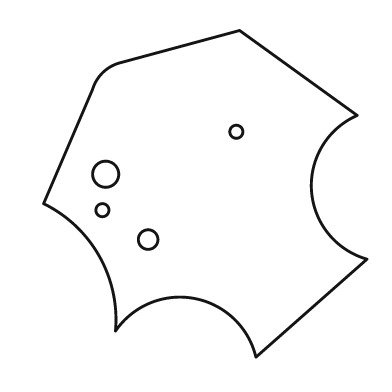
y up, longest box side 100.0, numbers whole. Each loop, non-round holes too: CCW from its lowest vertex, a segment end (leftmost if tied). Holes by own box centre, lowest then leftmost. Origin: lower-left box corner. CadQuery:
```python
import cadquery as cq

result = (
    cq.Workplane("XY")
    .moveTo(65.0, 0.0)
    .lineTo(99.0, 30.0)
    .threePointArc((82.0, 51.0), (96.0, 74.0))
    .lineTo(60.0, 100.0)
    .lineTo(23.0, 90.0)
    .threePointArc((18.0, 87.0), (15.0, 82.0))
    .lineTo(0.0, 47.0)
    .threePointArc((17.0, 31.0), (22.0, 8.0))
    .threePointArc((46.0, 18.0), (65.0, 0.0))
    .close()
    .moveTo(32.0, 36.0)
    .circle(3.0)
    .moveTo(18.0, 45.0)
    .circle(2.0)
    .moveTo(19.0, 56.0)
    .circle(4.0)
    .moveTo(59.0, 69.0)
    .circle(2.0)
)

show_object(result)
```